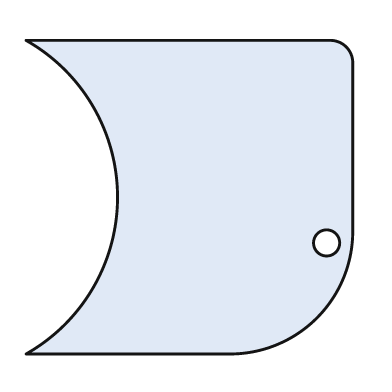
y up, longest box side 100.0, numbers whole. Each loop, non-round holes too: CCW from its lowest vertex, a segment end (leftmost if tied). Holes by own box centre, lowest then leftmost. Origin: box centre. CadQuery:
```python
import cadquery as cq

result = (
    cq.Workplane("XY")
    .moveTo(-50.0, -48.0)
    .lineTo(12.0, -48.0)
    .threePointArc((39.0, -37.0), (50.0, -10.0))
    .lineTo(50.0, 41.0)
    .threePointArc((48.0, 46.0), (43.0, 48.0))
    .lineTo(-50.0, 48.0)
    .threePointArc((-22.0, 0.0), (-50.0, -48.0))
    .close()
    .moveTo(42.0, -14.0)
    .circle(4.0)
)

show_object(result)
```